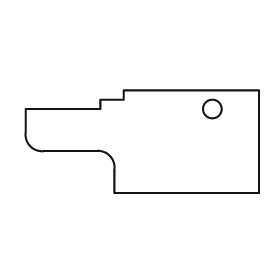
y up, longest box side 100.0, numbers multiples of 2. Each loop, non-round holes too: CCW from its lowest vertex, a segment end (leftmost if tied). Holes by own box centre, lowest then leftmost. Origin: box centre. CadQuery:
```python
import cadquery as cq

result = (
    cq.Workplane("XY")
    .moveTo(-12.0, -22.0)
    .lineTo(50.0, -22.0)
    .lineTo(50.0, 22.0)
    .lineTo(-8.0, 22.0)
    .lineTo(-8.0, 18.0)
    .lineTo(-18.0, 18.0)
    .lineTo(-18.0, 14.0)
    .lineTo(-50.0, 14.0)
    .lineTo(-50.0, 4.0)
    .threePointArc((-48.0, -2.0), (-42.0, -4.0))
    .lineTo(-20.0, -4.0)
    .threePointArc((-14.0, -6.0), (-12.0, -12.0))
    .close()
    .moveTo(30.0, 14.0)
    .circle(4.0)
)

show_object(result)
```